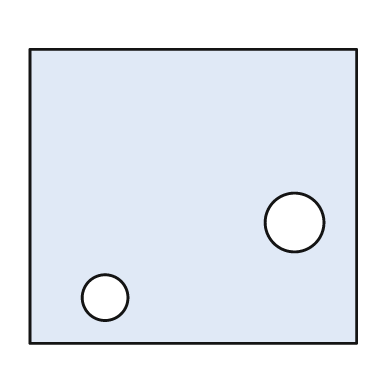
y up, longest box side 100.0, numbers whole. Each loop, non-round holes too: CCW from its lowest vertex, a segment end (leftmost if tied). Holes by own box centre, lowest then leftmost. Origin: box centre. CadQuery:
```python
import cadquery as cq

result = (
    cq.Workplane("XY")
    .moveTo(-50.0, -45.0)
    .lineTo(50.0, -45.0)
    .lineTo(50.0, 45.0)
    .lineTo(-50.0, 45.0)
    .close()
    .moveTo(-27.0, -31.0)
    .circle(7.0)
    .moveTo(31.0, -8.0)
    .circle(9.0)
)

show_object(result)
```